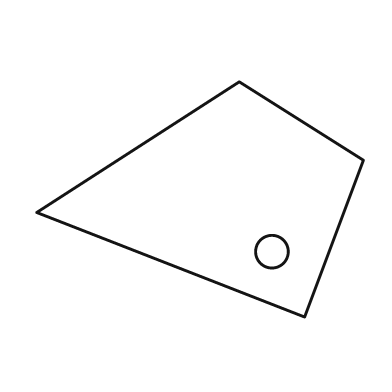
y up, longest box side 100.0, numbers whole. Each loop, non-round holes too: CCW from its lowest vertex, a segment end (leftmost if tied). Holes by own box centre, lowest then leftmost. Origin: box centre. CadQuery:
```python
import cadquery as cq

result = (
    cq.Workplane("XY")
    .moveTo(32.0, -36.0)
    .lineTo(50.0, 12.0)
    .lineTo(12.0, 36.0)
    .lineTo(-50.0, -4.0)
    .close()
    .moveTo(22.0, -16.0)
    .circle(5.0)
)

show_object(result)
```